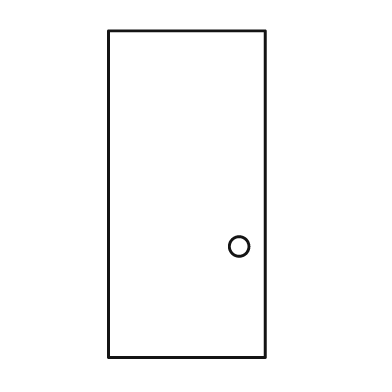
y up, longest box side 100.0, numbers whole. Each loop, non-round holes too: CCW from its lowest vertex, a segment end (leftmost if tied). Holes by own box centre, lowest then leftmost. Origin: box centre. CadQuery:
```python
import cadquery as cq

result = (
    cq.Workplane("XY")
    .moveTo(-24.0, -50.0)
    .lineTo(24.0, -50.0)
    .lineTo(24.0, 50.0)
    .lineTo(-24.0, 50.0)
    .close()
    .moveTo(16.0, -16.0)
    .circle(3.0)
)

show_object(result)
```